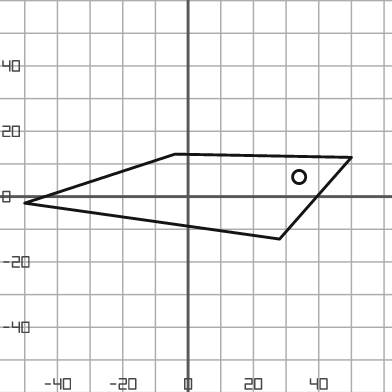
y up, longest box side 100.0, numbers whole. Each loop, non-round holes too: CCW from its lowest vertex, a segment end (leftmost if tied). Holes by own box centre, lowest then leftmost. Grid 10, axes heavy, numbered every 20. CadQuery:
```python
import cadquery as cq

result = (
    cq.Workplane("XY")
    .moveTo(28.0, -13.0)
    .lineTo(50.0, 12.0)
    .lineTo(-4.0, 13.0)
    .lineTo(-50.0, -2.0)
    .close()
    .moveTo(34.0, 6.0)
    .circle(2.0)
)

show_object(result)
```